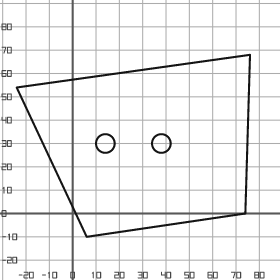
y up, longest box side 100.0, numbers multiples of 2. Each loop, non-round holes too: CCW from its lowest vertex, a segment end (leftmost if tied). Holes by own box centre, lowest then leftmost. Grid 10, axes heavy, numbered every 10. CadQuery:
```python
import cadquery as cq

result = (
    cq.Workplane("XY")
    .moveTo(6.0, -10.0)
    .lineTo(74.0, 0.0)
    .lineTo(76.0, 68.0)
    .lineTo(-24.0, 54.0)
    .close()
    .moveTo(14.0, 30.0)
    .circle(4.0)
    .moveTo(38.0, 30.0)
    .circle(4.0)
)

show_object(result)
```